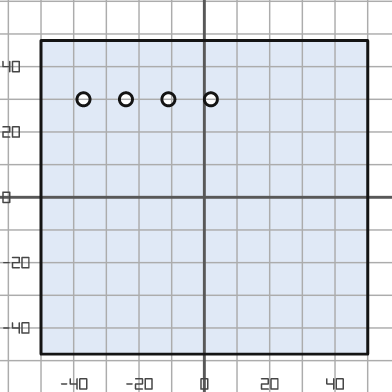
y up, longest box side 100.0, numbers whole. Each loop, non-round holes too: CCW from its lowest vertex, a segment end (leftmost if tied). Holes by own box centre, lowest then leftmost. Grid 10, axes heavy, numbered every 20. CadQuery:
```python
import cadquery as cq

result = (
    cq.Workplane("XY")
    .moveTo(-50.0, -48.0)
    .lineTo(50.0, -48.0)
    .lineTo(50.0, 48.0)
    .lineTo(-50.0, 48.0)
    .close()
    .moveTo(-37.0, 30.0)
    .circle(2.0)
    .moveTo(-24.0, 30.0)
    .circle(2.0)
    .moveTo(-11.0, 30.0)
    .circle(2.0)
    .moveTo(2.0, 30.0)
    .circle(2.0)
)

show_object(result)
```